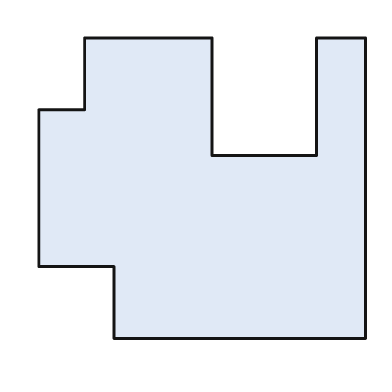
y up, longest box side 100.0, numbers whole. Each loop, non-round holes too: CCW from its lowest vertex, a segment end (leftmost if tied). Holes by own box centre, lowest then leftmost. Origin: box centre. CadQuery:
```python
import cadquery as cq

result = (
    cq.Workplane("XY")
    .moveTo(-27.0, -46.0)
    .lineTo(50.0, -46.0)
    .lineTo(50.0, 46.0)
    .lineTo(35.0, 46.0)
    .lineTo(35.0, 10.0)
    .lineTo(3.0, 10.0)
    .lineTo(3.0, 46.0)
    .lineTo(-36.0, 46.0)
    .lineTo(-36.0, 24.0)
    .lineTo(-50.0, 24.0)
    .lineTo(-50.0, -24.0)
    .lineTo(-27.0, -24.0)
    .close()
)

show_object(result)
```